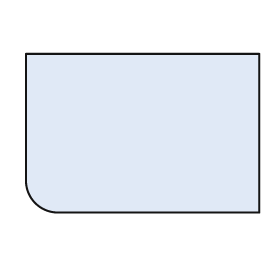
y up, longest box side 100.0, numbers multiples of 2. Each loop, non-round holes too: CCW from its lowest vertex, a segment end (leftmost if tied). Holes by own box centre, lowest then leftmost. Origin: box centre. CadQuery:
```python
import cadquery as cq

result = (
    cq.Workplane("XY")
    .moveTo(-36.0, -34.0)
    .lineTo(50.0, -34.0)
    .lineTo(50.0, 34.0)
    .lineTo(-50.0, 34.0)
    .lineTo(-50.0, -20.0)
    .threePointArc((-46.0, -30.0), (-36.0, -34.0))
    .close()
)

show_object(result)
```